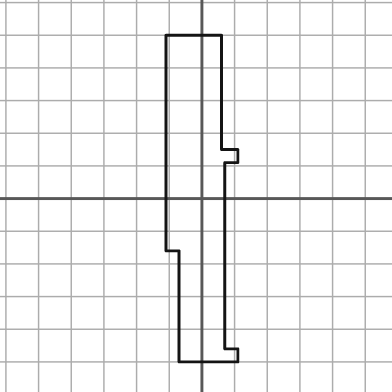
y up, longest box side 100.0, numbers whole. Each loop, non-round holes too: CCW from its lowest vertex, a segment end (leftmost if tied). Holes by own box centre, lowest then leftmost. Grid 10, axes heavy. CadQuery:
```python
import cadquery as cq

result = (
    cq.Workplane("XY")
    .moveTo(-7.0, -50.0)
    .lineTo(11.0, -50.0)
    .lineTo(11.0, -46.0)
    .lineTo(7.0, -46.0)
    .lineTo(7.0, 11.0)
    .lineTo(11.0, 11.0)
    .lineTo(11.0, 15.0)
    .lineTo(6.0, 15.0)
    .lineTo(6.0, 50.0)
    .lineTo(-11.0, 50.0)
    .lineTo(-11.0, -16.0)
    .lineTo(-7.0, -16.0)
    .close()
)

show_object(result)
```